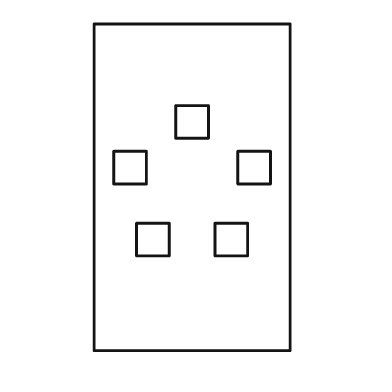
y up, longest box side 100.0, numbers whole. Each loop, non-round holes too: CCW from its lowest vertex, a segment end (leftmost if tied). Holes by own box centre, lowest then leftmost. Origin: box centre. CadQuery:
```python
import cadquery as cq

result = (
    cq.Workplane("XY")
    .moveTo(-30.0, -50.0)
    .lineTo(30.0, -50.0)
    .lineTo(30.0, 50.0)
    .lineTo(-30.0, 50.0)
    .close()
    .moveTo(-17.0, -21.0)
    .lineTo(-7.0, -21.0)
    .lineTo(-7.0, -11.0)
    .lineTo(-17.0, -11.0)
    .close()
    .moveTo(7.0, -21.0)
    .lineTo(17.0, -21.0)
    .lineTo(17.0, -11.0)
    .lineTo(7.0, -11.0)
    .close()
    .moveTo(-24.0, 1.0)
    .lineTo(-14.0, 1.0)
    .lineTo(-14.0, 11.0)
    .lineTo(-24.0, 11.0)
    .close()
    .moveTo(14.0, 1.0)
    .lineTo(24.0, 1.0)
    .lineTo(24.0, 11.0)
    .lineTo(14.0, 11.0)
    .close()
    .moveTo(-5.0, 15.0)
    .lineTo(5.0, 15.0)
    .lineTo(5.0, 25.0)
    .lineTo(-5.0, 25.0)
    .close()
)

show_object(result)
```